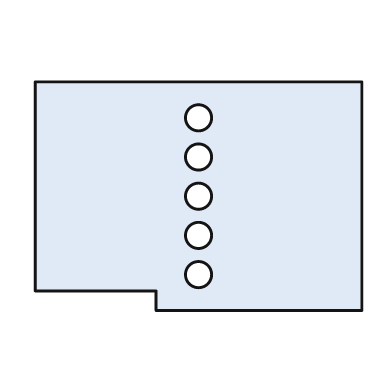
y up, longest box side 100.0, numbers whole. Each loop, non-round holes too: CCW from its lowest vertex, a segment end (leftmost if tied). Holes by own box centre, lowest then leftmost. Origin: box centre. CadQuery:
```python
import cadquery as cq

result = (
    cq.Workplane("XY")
    .moveTo(-13.0, -35.0)
    .lineTo(50.0, -35.0)
    .lineTo(50.0, 35.0)
    .lineTo(-50.0, 35.0)
    .lineTo(-50.0, -29.0)
    .lineTo(-13.0, -29.0)
    .close()
    .moveTo(0.0, -24.0)
    .circle(4.0)
    .moveTo(0.0, -12.0)
    .circle(4.0)
    .moveTo(0.0, 0.0)
    .circle(4.0)
    .moveTo(0.0, 12.0)
    .circle(4.0)
    .moveTo(0.0, 24.0)
    .circle(4.0)
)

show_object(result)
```